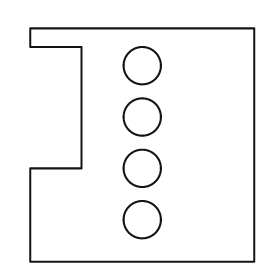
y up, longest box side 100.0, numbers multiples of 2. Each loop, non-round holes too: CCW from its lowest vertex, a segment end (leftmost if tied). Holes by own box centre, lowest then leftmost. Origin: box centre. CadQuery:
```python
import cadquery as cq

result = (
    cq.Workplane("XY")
    .moveTo(-48.0, -50.0)
    .lineTo(48.0, -50.0)
    .lineTo(48.0, 50.0)
    .lineTo(-48.0, 50.0)
    .lineTo(-48.0, 42.0)
    .lineTo(-26.0, 42.0)
    .lineTo(-26.0, -10.0)
    .lineTo(-48.0, -10.0)
    .close()
    .moveTo(0.0, -32.0)
    .circle(8.0)
    .moveTo(0.0, -10.0)
    .circle(8.0)
    .moveTo(0.0, 12.0)
    .circle(8.0)
    .moveTo(0.0, 34.0)
    .circle(8.0)
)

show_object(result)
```